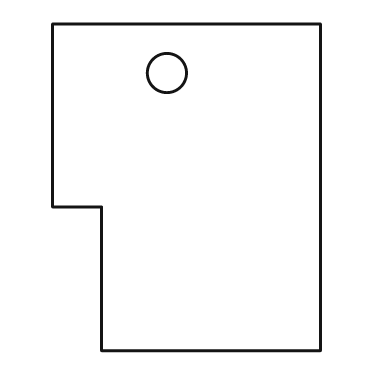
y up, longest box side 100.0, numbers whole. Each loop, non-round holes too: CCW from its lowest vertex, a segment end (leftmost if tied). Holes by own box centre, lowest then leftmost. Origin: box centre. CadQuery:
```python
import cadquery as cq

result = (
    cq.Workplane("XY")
    .moveTo(-26.0, -50.0)
    .lineTo(41.0, -50.0)
    .lineTo(41.0, 50.0)
    .lineTo(-41.0, 50.0)
    .lineTo(-41.0, -6.0)
    .lineTo(-26.0, -6.0)
    .close()
    .moveTo(-6.0, 35.0)
    .circle(6.0)
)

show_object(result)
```